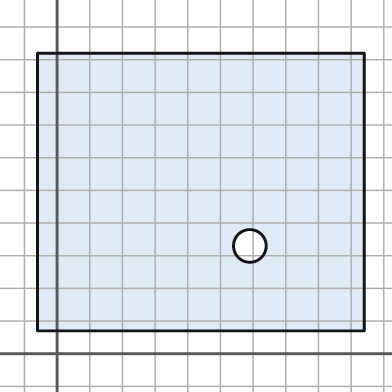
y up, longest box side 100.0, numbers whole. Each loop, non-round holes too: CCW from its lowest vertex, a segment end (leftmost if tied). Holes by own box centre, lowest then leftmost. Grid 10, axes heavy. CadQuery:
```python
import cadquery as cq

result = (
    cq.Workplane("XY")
    .moveTo(-6.0, 7.0)
    .lineTo(94.0, 7.0)
    .lineTo(94.0, 92.0)
    .lineTo(-6.0, 92.0)
    .close()
    .moveTo(59.0, 33.0)
    .circle(5.0)
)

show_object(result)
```